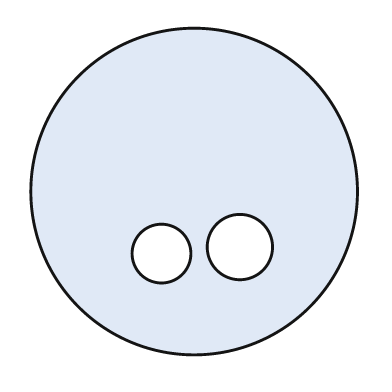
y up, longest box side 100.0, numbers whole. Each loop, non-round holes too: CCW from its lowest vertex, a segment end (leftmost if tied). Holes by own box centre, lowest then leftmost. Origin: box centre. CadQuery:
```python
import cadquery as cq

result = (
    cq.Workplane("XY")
    .moveTo(0.0, 0.0)
    .circle(50.0)
    .moveTo(-10.0, -19.0)
    .circle(9.0)
    .moveTo(14.0, -17.0)
    .circle(10.0)
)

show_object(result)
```